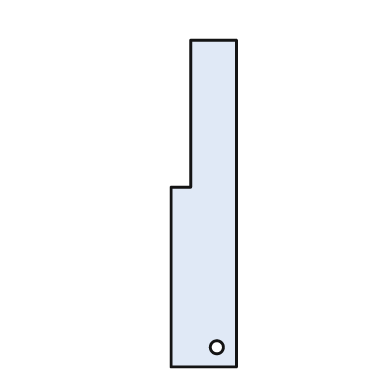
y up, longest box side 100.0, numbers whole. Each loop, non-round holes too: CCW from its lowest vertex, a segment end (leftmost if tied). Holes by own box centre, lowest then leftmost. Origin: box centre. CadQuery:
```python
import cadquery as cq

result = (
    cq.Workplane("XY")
    .moveTo(-10.0, -50.0)
    .lineTo(10.0, -50.0)
    .lineTo(10.0, 50.0)
    .lineTo(-4.0, 50.0)
    .lineTo(-4.0, 5.0)
    .lineTo(-10.0, 5.0)
    .close()
    .moveTo(4.0, -44.0)
    .circle(2.0)
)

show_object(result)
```